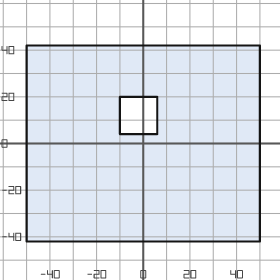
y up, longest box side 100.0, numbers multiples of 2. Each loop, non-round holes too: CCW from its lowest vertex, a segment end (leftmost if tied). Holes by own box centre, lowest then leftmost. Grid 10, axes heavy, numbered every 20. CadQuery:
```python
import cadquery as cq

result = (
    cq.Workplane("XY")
    .moveTo(-50.0, -42.0)
    .lineTo(50.0, -42.0)
    .lineTo(50.0, 42.0)
    .lineTo(-50.0, 42.0)
    .close()
    .moveTo(-10.0, 4.0)
    .lineTo(6.0, 4.0)
    .lineTo(6.0, 20.0)
    .lineTo(-10.0, 20.0)
    .close()
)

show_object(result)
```